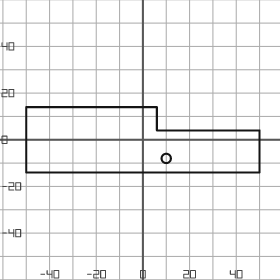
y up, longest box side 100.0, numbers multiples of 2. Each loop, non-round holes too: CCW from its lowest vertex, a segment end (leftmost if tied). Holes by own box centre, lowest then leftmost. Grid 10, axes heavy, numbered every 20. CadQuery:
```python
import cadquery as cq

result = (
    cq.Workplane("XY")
    .moveTo(-50.0, -14.0)
    .lineTo(50.0, -14.0)
    .lineTo(50.0, 4.0)
    .lineTo(6.0, 4.0)
    .lineTo(6.0, 14.0)
    .lineTo(-50.0, 14.0)
    .close()
    .moveTo(10.0, -8.0)
    .circle(2.0)
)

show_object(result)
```